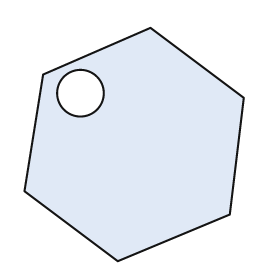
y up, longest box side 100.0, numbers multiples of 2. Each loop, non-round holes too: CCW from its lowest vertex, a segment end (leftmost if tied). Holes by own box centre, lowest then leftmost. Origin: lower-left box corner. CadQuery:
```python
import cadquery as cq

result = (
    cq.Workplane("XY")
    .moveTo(40.0, 0.0)
    .lineTo(88.0, 20.0)
    .lineTo(94.0, 70.0)
    .lineTo(54.0, 100.0)
    .lineTo(8.0, 80.0)
    .lineTo(0.0, 30.0)
    .close()
    .moveTo(24.0, 72.0)
    .circle(10.0)
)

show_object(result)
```